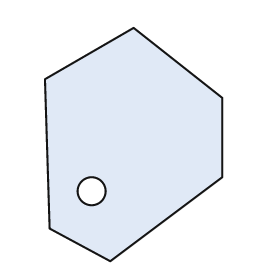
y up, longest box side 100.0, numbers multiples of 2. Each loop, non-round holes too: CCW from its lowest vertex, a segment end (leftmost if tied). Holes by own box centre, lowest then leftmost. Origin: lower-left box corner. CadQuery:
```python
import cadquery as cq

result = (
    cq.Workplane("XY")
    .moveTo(28.0, 0.0)
    .lineTo(76.0, 36.0)
    .lineTo(76.0, 70.0)
    .lineTo(38.0, 100.0)
    .lineTo(0.0, 78.0)
    .lineTo(2.0, 14.0)
    .close()
    .moveTo(20.0, 30.0)
    .circle(6.0)
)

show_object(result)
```